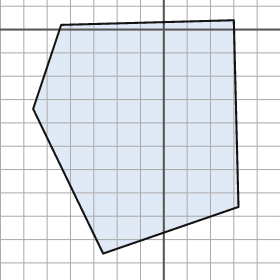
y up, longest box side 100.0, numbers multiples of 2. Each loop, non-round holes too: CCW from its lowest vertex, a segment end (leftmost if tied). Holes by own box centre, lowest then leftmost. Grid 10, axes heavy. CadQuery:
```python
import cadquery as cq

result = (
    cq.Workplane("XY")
    .moveTo(-26.0, -96.0)
    .lineTo(32.0, -76.0)
    .lineTo(30.0, 4.0)
    .lineTo(-44.0, 2.0)
    .lineTo(-56.0, -34.0)
    .close()
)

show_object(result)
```